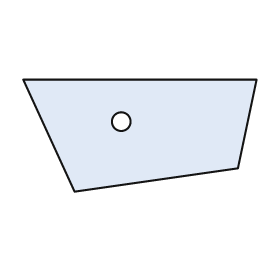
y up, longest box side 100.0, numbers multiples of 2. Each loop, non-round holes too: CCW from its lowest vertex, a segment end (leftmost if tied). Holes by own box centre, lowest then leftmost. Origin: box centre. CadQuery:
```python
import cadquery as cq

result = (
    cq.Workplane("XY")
    .moveTo(-28.0, -24.0)
    .lineTo(42.0, -14.0)
    .lineTo(50.0, 24.0)
    .lineTo(-50.0, 24.0)
    .close()
    .moveTo(-8.0, 6.0)
    .circle(4.0)
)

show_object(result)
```